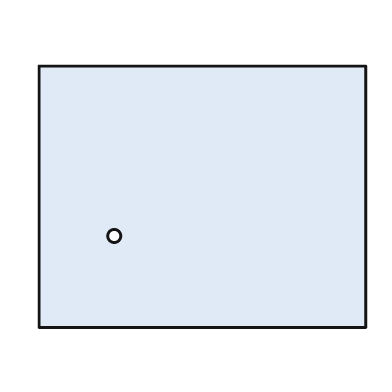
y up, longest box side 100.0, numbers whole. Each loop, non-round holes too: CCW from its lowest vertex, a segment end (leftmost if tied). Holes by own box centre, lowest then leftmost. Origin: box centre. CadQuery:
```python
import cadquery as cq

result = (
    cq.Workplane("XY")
    .moveTo(-50.0, -40.0)
    .lineTo(50.0, -40.0)
    .lineTo(50.0, 40.0)
    .lineTo(-50.0, 40.0)
    .close()
    .moveTo(-27.0, -12.0)
    .circle(2.0)
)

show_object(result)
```